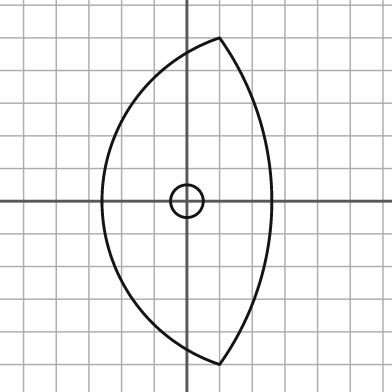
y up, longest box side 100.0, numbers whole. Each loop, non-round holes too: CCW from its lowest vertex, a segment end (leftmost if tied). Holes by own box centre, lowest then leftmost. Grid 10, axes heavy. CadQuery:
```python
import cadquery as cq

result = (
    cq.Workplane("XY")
    .moveTo(10.0, -50.0)
    .threePointArc((26.0, 0.0), (10.0, 50.0))
    .threePointArc((-26.0, 0.0), (10.0, -50.0))
    .close()
    .moveTo(0.0, 0.0)
    .circle(5.0)
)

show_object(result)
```